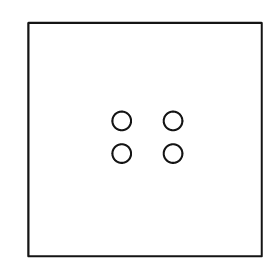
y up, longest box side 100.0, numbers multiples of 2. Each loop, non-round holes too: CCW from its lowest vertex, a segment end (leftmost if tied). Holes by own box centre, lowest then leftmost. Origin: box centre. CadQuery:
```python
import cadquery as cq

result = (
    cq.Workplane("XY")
    .moveTo(-50.0, -50.0)
    .lineTo(50.0, -50.0)
    .lineTo(50.0, 50.0)
    .lineTo(-50.0, 50.0)
    .close()
    .moveTo(-10.0, -6.0)
    .circle(4.0)
    .moveTo(12.0, -6.0)
    .circle(4.0)
    .moveTo(-10.0, 8.0)
    .circle(4.0)
    .moveTo(12.0, 8.0)
    .circle(4.0)
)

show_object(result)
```